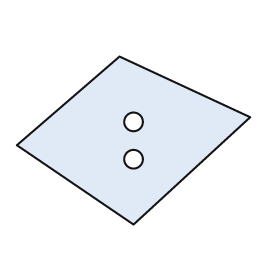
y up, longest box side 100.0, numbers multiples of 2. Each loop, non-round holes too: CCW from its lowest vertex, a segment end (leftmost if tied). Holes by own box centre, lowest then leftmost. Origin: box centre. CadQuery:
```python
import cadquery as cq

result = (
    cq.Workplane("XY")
    .moveTo(0.0, -36.0)
    .lineTo(50.0, 10.0)
    .lineTo(-6.0, 36.0)
    .lineTo(-50.0, -2.0)
    .close()
    .moveTo(0.0, -8.0)
    .circle(4.0)
    .moveTo(0.0, 8.0)
    .circle(4.0)
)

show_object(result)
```